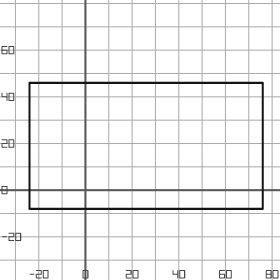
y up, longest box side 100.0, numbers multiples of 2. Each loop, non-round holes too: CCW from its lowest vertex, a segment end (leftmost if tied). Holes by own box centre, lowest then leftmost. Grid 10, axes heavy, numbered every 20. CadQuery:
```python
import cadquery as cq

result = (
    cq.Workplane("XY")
    .moveTo(-24.0, -8.0)
    .lineTo(76.0, -8.0)
    .lineTo(76.0, 46.0)
    .lineTo(-24.0, 46.0)
    .close()
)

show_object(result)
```